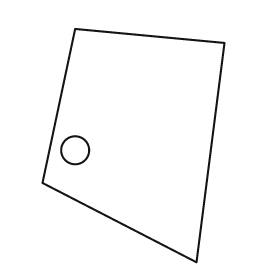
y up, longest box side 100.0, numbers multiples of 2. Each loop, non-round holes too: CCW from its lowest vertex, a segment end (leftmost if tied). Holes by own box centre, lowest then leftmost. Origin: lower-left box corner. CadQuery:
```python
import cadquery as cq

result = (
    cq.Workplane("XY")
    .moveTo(66.0, 0.0)
    .lineTo(78.0, 94.0)
    .lineTo(14.0, 100.0)
    .lineTo(0.0, 34.0)
    .close()
    .moveTo(14.0, 48.0)
    .circle(6.0)
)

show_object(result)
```